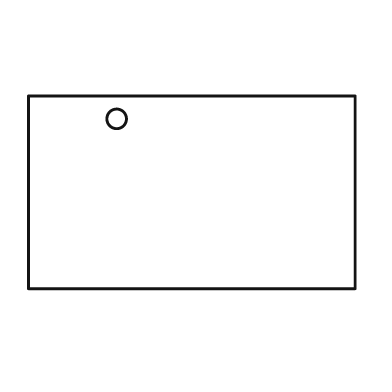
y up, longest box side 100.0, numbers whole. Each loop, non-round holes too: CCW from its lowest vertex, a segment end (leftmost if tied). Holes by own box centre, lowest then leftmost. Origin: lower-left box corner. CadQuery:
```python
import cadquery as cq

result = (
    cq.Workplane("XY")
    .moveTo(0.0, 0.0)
    .lineTo(100.0, 0.0)
    .lineTo(100.0, 59.0)
    .lineTo(0.0, 59.0)
    .close()
    .moveTo(27.0, 52.0)
    .circle(3.0)
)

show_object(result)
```